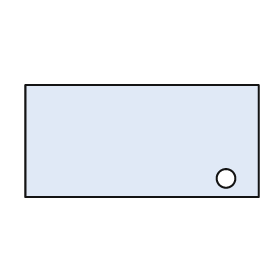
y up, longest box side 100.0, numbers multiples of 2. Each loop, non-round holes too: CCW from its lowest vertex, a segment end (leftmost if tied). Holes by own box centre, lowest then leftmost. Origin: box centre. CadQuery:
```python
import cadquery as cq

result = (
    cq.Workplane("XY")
    .moveTo(-50.0, -24.0)
    .lineTo(50.0, -24.0)
    .lineTo(50.0, 24.0)
    .lineTo(-50.0, 24.0)
    .close()
    .moveTo(36.0, -16.0)
    .circle(4.0)
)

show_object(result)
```